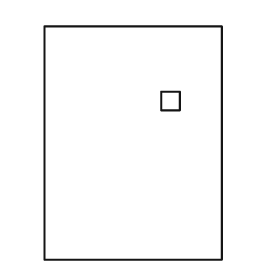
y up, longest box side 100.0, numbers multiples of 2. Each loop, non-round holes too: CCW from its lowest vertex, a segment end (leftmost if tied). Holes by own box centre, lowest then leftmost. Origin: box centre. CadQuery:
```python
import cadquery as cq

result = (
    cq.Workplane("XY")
    .moveTo(-38.0, -50.0)
    .lineTo(38.0, -50.0)
    .lineTo(38.0, 50.0)
    .lineTo(-38.0, 50.0)
    .close()
    .moveTo(12.0, 14.0)
    .lineTo(20.0, 14.0)
    .lineTo(20.0, 22.0)
    .lineTo(12.0, 22.0)
    .close()
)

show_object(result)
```